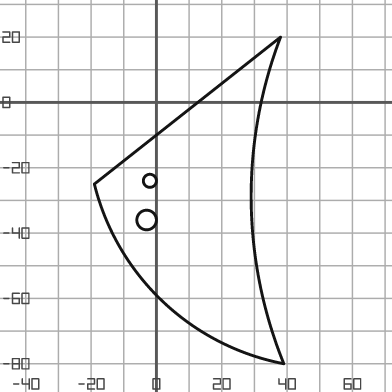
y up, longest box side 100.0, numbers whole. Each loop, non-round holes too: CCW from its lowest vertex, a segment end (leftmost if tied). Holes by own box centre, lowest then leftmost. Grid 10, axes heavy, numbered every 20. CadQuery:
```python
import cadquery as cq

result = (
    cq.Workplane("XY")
    .moveTo(39.0, -80.0)
    .threePointArc((29.0, -30.0), (38.0, 20.0))
    .lineTo(-19.0, -25.0)
    .threePointArc((2.0, -61.0), (39.0, -80.0))
    .close()
    .moveTo(-3.0, -36.0)
    .circle(3.0)
    .moveTo(-2.0, -24.0)
    .circle(2.0)
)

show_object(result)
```